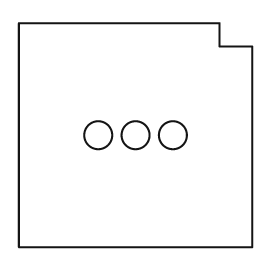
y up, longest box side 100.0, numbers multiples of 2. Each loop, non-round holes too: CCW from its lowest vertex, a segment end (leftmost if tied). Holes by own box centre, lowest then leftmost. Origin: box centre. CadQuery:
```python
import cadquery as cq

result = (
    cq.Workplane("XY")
    .moveTo(-50.0, -48.0)
    .lineTo(50.0, -48.0)
    .lineTo(50.0, 38.0)
    .lineTo(36.0, 38.0)
    .lineTo(36.0, 48.0)
    .lineTo(-50.0, 48.0)
    .close()
    .moveTo(-16.0, 0.0)
    .circle(6.0)
    .moveTo(0.0, 0.0)
    .circle(6.0)
    .moveTo(16.0, 0.0)
    .circle(6.0)
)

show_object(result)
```